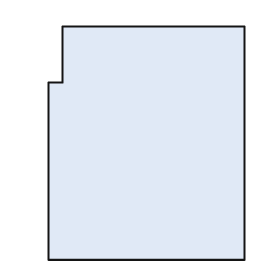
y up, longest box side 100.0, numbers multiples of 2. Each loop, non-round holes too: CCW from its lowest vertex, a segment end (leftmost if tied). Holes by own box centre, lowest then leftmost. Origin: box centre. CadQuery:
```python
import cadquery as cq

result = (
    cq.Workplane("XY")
    .moveTo(-42.0, -50.0)
    .lineTo(42.0, -50.0)
    .lineTo(42.0, 50.0)
    .lineTo(-36.0, 50.0)
    .lineTo(-36.0, 26.0)
    .lineTo(-42.0, 26.0)
    .close()
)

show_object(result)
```